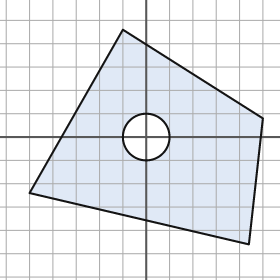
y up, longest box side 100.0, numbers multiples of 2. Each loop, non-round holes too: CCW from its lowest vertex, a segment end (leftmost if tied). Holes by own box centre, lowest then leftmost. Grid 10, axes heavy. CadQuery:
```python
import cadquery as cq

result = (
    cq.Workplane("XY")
    .moveTo(44.0, -46.0)
    .lineTo(50.0, 8.0)
    .lineTo(-10.0, 46.0)
    .lineTo(-50.0, -24.0)
    .close()
    .moveTo(0.0, 0.0)
    .circle(10.0)
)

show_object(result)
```